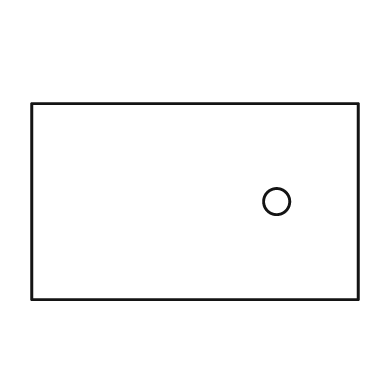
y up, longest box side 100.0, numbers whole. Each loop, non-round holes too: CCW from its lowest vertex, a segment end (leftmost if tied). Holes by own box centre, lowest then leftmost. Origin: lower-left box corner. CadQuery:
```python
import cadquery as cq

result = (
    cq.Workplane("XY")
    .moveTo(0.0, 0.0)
    .lineTo(100.0, 0.0)
    .lineTo(100.0, 60.0)
    .lineTo(0.0, 60.0)
    .close()
    .moveTo(75.0, 30.0)
    .circle(4.0)
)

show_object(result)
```